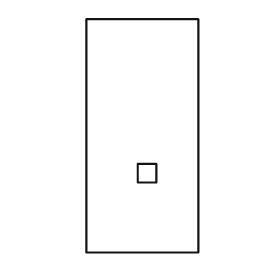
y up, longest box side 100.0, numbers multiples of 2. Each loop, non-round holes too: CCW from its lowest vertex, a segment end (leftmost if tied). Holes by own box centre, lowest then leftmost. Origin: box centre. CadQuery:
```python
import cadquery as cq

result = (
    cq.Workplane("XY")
    .moveTo(-24.0, -50.0)
    .lineTo(24.0, -50.0)
    .lineTo(24.0, 50.0)
    .lineTo(-24.0, 50.0)
    .close()
    .moveTo(-2.0, -20.0)
    .lineTo(6.0, -20.0)
    .lineTo(6.0, -12.0)
    .lineTo(-2.0, -12.0)
    .close()
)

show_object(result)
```